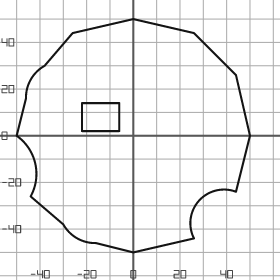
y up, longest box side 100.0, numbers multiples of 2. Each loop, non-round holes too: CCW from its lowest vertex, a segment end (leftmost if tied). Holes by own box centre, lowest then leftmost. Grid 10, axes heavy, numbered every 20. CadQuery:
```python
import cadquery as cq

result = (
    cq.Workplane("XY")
    .moveTo(0.0, -50.0)
    .lineTo(26.0, -44.0)
    .threePointArc((28.0, -28.0), (44.0, -24.0))
    .lineTo(50.0, 0.0)
    .lineTo(44.0, 26.0)
    .lineTo(26.0, 44.0)
    .lineTo(0.0, 50.0)
    .lineTo(-26.0, 44.0)
    .lineTo(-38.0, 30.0)
    .threePointArc((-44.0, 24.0), (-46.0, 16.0))
    .lineTo(-50.0, 0.0)
    .threePointArc((-42.0, -12.0), (-44.0, -26.0))
    .lineTo(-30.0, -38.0)
    .threePointArc((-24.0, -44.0), (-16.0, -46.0))
    .close()
    .moveTo(-22.0, 2.0)
    .lineTo(-6.0, 2.0)
    .lineTo(-6.0, 14.0)
    .lineTo(-22.0, 14.0)
    .close()
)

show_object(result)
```